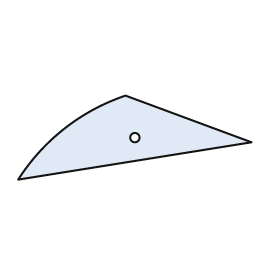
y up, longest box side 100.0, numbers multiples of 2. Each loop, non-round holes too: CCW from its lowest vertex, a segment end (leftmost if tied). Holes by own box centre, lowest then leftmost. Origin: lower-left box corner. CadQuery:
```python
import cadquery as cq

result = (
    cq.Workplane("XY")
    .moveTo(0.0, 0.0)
    .lineTo(100.0, 16.0)
    .lineTo(46.0, 36.0)
    .threePointArc((20.0, 22.0), (0.0, 0.0))
    .close()
    .moveTo(50.0, 18.0)
    .circle(2.0)
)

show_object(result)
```